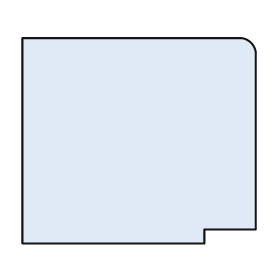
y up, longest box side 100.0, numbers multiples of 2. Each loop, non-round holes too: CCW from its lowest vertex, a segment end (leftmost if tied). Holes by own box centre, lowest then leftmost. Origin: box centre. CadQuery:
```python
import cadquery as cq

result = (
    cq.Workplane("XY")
    .moveTo(-50.0, -44.0)
    .lineTo(28.0, -44.0)
    .lineTo(28.0, -38.0)
    .lineTo(50.0, -38.0)
    .lineTo(50.0, 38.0)
    .threePointArc((48.0, 42.0), (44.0, 44.0))
    .lineTo(-50.0, 44.0)
    .close()
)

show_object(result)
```